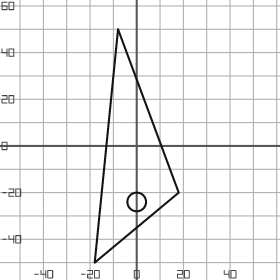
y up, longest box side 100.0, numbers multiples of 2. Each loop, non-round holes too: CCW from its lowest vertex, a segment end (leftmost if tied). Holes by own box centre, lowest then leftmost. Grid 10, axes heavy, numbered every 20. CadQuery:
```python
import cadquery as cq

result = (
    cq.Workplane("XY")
    .moveTo(-18.0, -50.0)
    .lineTo(18.0, -20.0)
    .lineTo(-8.0, 50.0)
    .close()
    .moveTo(0.0, -24.0)
    .circle(4.0)
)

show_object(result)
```